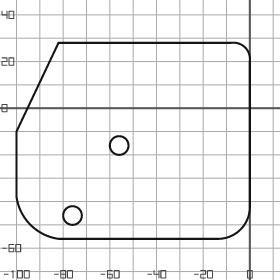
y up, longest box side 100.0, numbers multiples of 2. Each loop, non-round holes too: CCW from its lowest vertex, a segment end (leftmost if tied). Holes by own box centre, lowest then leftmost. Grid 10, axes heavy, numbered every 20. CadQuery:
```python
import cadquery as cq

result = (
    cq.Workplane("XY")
    .moveTo(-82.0, -56.0)
    .lineTo(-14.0, -56.0)
    .threePointArc((-4.0, -52.0), (0.0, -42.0))
    .lineTo(0.0, 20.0)
    .threePointArc((-2.0, 26.0), (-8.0, 28.0))
    .lineTo(-82.0, 28.0)
    .lineTo(-100.0, -10.0)
    .lineTo(-100.0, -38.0)
    .threePointArc((-94.0, -50.0), (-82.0, -56.0))
    .close()
    .moveTo(-76.0, -46.0)
    .circle(4.0)
    .moveTo(-56.0, -16.0)
    .circle(4.0)
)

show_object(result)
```